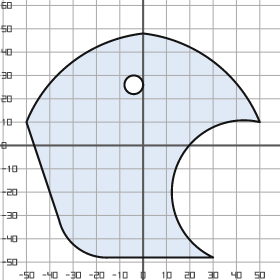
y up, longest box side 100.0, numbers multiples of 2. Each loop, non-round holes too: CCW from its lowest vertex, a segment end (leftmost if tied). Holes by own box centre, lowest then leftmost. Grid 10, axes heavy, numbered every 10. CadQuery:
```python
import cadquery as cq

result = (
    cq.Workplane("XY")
    .moveTo(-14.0, -48.0)
    .lineTo(30.0, -48.0)
    .threePointArc((14.0, -10.0), (50.0, 10.0))
    .threePointArc((30.0, 36.0), (0.0, 48.0))
    .threePointArc((-30.0, 36.0), (-50.0, 10.0))
    .lineTo(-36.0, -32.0)
    .threePointArc((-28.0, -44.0), (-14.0, -48.0))
    .close()
    .moveTo(-4.0, 26.0)
    .circle(4.0)
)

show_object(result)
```